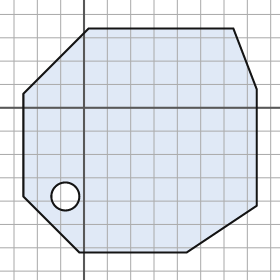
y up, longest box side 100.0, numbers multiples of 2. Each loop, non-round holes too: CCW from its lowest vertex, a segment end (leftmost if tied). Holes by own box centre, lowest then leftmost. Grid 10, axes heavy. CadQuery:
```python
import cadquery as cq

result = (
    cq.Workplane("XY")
    .moveTo(-2.0, -62.0)
    .lineTo(44.0, -62.0)
    .lineTo(74.0, -42.0)
    .lineTo(74.0, 8.0)
    .lineTo(64.0, 34.0)
    .lineTo(2.0, 34.0)
    .lineTo(-26.0, 6.0)
    .lineTo(-26.0, -38.0)
    .close()
    .moveTo(-8.0, -38.0)
    .circle(6.0)
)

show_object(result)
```